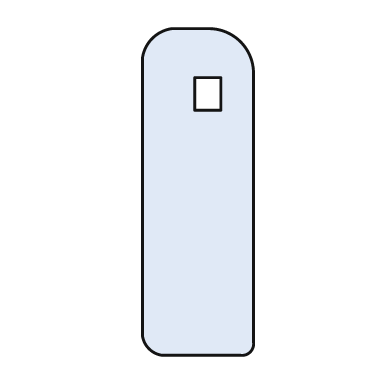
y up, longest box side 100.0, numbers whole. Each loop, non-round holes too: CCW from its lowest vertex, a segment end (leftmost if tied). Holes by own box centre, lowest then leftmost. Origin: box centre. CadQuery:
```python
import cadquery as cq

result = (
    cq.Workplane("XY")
    .moveTo(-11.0, -50.0)
    .lineTo(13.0, -50.0)
    .threePointArc((16.0, -49.0), (17.0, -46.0))
    .lineTo(17.0, 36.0)
    .threePointArc((13.0, 46.0), (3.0, 50.0))
    .lineTo(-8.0, 50.0)
    .threePointArc((-14.0, 47.0), (-17.0, 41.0))
    .lineTo(-17.0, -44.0)
    .threePointArc((-15.0, -48.0), (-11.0, -50.0))
    .close()
    .moveTo(-1.0, 25.0)
    .lineTo(7.0, 25.0)
    .lineTo(7.0, 35.0)
    .lineTo(-1.0, 35.0)
    .close()
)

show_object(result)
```